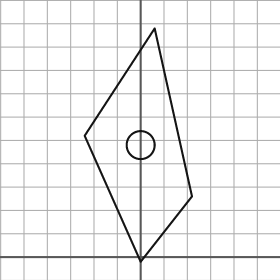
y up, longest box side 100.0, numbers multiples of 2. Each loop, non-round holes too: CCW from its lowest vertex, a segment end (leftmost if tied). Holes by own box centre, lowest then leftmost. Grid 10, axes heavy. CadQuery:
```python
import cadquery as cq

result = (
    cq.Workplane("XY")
    .moveTo(0.0, -2.0)
    .lineTo(22.0, 26.0)
    .lineTo(6.0, 98.0)
    .lineTo(-24.0, 52.0)
    .close()
    .moveTo(0.0, 48.0)
    .circle(6.0)
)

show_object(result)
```